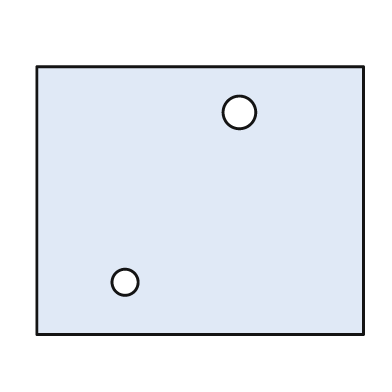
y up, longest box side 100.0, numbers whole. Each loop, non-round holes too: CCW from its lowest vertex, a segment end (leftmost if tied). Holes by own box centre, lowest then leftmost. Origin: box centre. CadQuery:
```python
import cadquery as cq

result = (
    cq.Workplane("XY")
    .moveTo(-50.0, -41.0)
    .lineTo(50.0, -41.0)
    .lineTo(50.0, 41.0)
    .lineTo(-50.0, 41.0)
    .close()
    .moveTo(-23.0, -25.0)
    .circle(4.0)
    .moveTo(12.0, 27.0)
    .circle(5.0)
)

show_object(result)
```